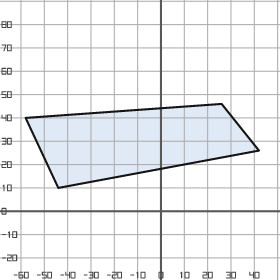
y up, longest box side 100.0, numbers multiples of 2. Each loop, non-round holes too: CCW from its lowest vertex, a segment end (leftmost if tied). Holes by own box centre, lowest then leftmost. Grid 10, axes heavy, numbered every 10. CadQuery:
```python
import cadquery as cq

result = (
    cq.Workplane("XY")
    .moveTo(-44.0, 10.0)
    .lineTo(42.0, 26.0)
    .lineTo(26.0, 46.0)
    .lineTo(-58.0, 40.0)
    .close()
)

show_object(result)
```